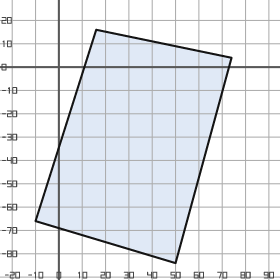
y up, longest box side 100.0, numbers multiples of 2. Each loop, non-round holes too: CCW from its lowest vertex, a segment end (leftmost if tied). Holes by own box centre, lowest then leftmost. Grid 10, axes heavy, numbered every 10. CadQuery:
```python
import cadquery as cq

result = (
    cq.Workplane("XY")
    .moveTo(50.0, -84.0)
    .lineTo(74.0, 4.0)
    .lineTo(16.0, 16.0)
    .lineTo(-10.0, -66.0)
    .close()
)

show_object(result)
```